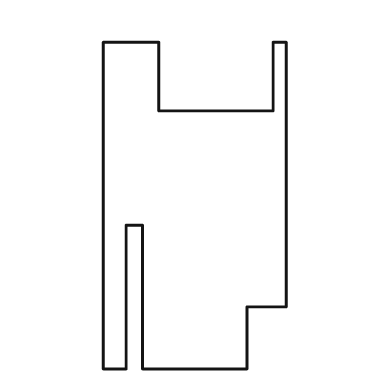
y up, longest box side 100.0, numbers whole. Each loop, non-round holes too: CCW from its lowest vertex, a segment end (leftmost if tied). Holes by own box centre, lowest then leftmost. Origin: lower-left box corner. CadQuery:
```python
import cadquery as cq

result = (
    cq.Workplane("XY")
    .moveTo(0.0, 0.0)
    .lineTo(7.0, 0.0)
    .lineTo(7.0, 44.0)
    .lineTo(12.0, 44.0)
    .lineTo(12.0, 0.0)
    .lineTo(44.0, 0.0)
    .lineTo(44.0, 19.0)
    .lineTo(56.0, 19.0)
    .lineTo(56.0, 100.0)
    .lineTo(52.0, 100.0)
    .lineTo(52.0, 79.0)
    .lineTo(17.0, 79.0)
    .lineTo(17.0, 100.0)
    .lineTo(0.0, 100.0)
    .close()
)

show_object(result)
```